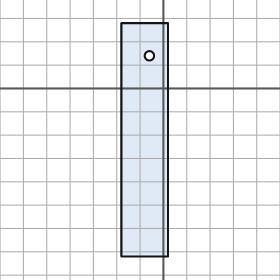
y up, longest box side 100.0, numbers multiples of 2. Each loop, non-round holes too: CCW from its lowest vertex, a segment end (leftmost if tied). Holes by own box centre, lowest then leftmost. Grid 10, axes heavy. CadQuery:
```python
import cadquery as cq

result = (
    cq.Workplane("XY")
    .moveTo(-18.0, -72.0)
    .lineTo(2.0, -72.0)
    .lineTo(2.0, 28.0)
    .lineTo(-18.0, 28.0)
    .close()
    .moveTo(-6.0, 14.0)
    .circle(2.0)
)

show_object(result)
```